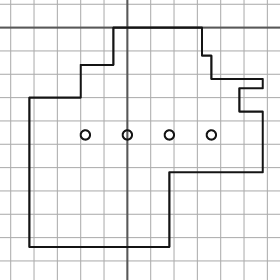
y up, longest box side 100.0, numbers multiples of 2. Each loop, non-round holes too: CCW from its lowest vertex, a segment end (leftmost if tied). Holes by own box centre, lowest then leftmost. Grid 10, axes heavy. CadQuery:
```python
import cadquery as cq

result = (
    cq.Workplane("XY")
    .moveTo(-42.0, -94.0)
    .lineTo(18.0, -94.0)
    .lineTo(18.0, -62.0)
    .lineTo(58.0, -62.0)
    .lineTo(58.0, -36.0)
    .lineTo(48.0, -36.0)
    .lineTo(48.0, -26.0)
    .lineTo(58.0, -26.0)
    .lineTo(58.0, -22.0)
    .lineTo(36.0, -22.0)
    .lineTo(36.0, -12.0)
    .lineTo(32.0, -12.0)
    .lineTo(32.0, 0.0)
    .lineTo(-6.0, 0.0)
    .lineTo(-6.0, -16.0)
    .lineTo(-20.0, -16.0)
    .lineTo(-20.0, -30.0)
    .lineTo(-42.0, -30.0)
    .close()
    .moveTo(-18.0, -46.0)
    .circle(2.0)
    .moveTo(0.0, -46.0)
    .circle(2.0)
    .moveTo(18.0, -46.0)
    .circle(2.0)
    .moveTo(36.0, -46.0)
    .circle(2.0)
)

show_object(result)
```